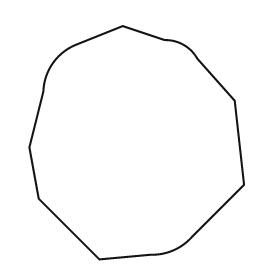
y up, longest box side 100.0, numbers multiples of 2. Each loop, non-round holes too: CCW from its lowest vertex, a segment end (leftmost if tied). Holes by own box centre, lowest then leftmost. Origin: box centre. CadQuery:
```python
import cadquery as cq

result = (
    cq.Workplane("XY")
    .moveTo(-16.0, -50.0)
    .lineTo(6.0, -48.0)
    .threePointArc((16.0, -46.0), (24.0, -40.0))
    .lineTo(46.0, -18.0)
    .lineTo(42.0, 18.0)
    .lineTo(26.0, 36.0)
    .threePointArc((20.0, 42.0), (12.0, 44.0))
    .lineTo(-6.0, 50.0)
    .lineTo(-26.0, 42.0)
    .threePointArc((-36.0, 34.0), (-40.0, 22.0))
    .lineTo(-46.0, -2.0)
    .lineTo(-42.0, -24.0)
    .close()
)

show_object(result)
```